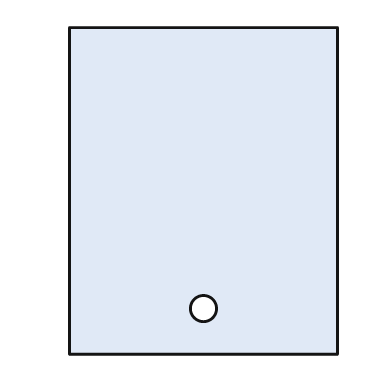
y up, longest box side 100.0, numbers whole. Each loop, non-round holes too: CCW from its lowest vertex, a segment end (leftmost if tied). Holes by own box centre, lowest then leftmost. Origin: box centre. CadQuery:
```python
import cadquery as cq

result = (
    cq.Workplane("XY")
    .moveTo(-41.0, -50.0)
    .lineTo(41.0, -50.0)
    .lineTo(41.0, 50.0)
    .lineTo(-41.0, 50.0)
    .close()
    .moveTo(0.0, -36.0)
    .circle(4.0)
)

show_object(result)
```